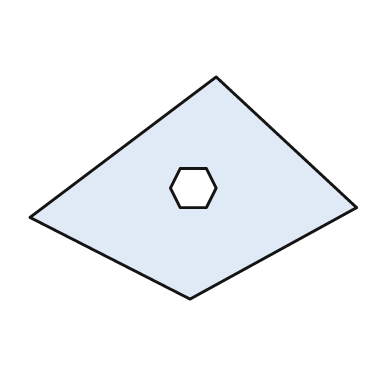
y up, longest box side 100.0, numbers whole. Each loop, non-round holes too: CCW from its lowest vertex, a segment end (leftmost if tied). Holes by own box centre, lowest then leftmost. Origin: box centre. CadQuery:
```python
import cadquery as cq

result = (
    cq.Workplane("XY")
    .moveTo(-1.0, -34.0)
    .lineTo(50.0, -6.0)
    .lineTo(7.0, 34.0)
    .lineTo(-50.0, -9.0)
    .close()
    .moveTo(-4.0, -6.0)
    .lineTo(4.0, -6.0)
    .lineTo(7.0, 0.0)
    .lineTo(4.0, 6.0)
    .lineTo(-4.0, 6.0)
    .lineTo(-7.0, 0.0)
    .close()
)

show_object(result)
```